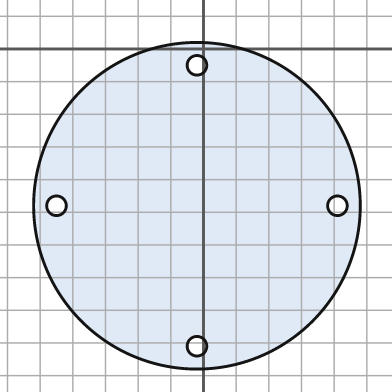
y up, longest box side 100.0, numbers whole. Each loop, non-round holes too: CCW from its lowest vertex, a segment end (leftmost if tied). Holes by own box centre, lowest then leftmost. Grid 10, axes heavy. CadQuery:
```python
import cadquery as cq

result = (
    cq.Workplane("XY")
    .moveTo(-2.0, -48.0)
    .circle(50.0)
    .moveTo(-2.0, -91.0)
    .circle(3.0)
    .moveTo(-45.0, -48.0)
    .circle(3.0)
    .moveTo(41.0, -48.0)
    .circle(3.0)
    .moveTo(-2.0, -5.0)
    .circle(3.0)
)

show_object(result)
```